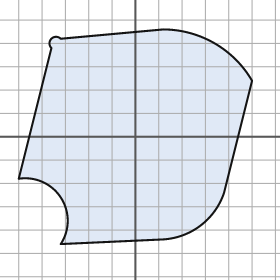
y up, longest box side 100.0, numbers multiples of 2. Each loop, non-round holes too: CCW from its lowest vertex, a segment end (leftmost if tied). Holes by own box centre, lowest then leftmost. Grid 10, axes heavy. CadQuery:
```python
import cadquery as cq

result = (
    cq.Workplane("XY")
    .moveTo(-32.0, -46.0)
    .lineTo(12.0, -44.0)
    .threePointArc((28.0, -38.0), (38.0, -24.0))
    .lineTo(50.0, 24.0)
    .threePointArc((34.0, 40.0), (12.0, 46.0))
    .lineTo(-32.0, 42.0)
    .threePointArc((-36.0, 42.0), (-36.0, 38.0))
    .lineTo(-50.0, -18.0)
    .threePointArc((-32.0, -26.0), (-32.0, -46.0))
    .close()
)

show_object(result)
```